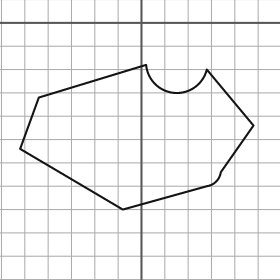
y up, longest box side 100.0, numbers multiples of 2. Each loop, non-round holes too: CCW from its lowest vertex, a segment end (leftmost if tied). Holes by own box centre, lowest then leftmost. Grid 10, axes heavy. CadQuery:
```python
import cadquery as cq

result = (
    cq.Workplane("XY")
    .moveTo(-8.0, -80.0)
    .lineTo(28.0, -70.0)
    .threePointArc((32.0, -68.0), (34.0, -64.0))
    .lineTo(48.0, -44.0)
    .lineTo(28.0, -20.0)
    .threePointArc((14.0, -30.0), (2.0, -18.0))
    .lineTo(-44.0, -32.0)
    .lineTo(-52.0, -54.0)
    .close()
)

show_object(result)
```